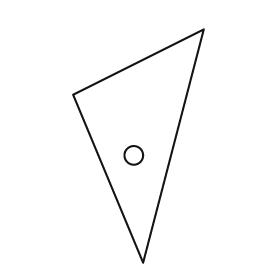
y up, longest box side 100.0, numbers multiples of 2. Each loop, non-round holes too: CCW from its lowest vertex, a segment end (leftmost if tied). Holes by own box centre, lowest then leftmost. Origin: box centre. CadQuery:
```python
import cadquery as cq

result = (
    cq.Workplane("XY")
    .moveTo(2.0, -50.0)
    .lineTo(28.0, 50.0)
    .lineTo(-28.0, 22.0)
    .close()
    .moveTo(-2.0, -4.0)
    .circle(4.0)
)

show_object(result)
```